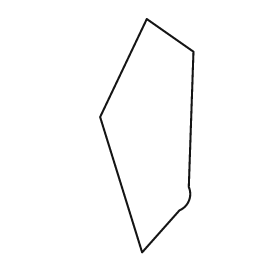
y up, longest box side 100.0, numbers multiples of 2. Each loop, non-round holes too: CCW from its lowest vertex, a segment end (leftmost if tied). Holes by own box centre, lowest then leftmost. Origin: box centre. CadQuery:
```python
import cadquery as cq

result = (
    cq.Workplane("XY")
    .moveTo(-2.0, -50.0)
    .lineTo(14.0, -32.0)
    .threePointArc((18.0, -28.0), (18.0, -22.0))
    .lineTo(20.0, 36.0)
    .lineTo(0.0, 50.0)
    .lineTo(-20.0, 8.0)
    .close()
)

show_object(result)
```